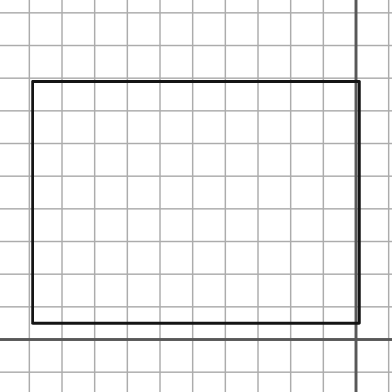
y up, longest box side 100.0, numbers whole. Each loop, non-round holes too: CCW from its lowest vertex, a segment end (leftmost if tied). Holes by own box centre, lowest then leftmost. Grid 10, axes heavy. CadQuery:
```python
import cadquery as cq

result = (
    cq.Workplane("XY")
    .moveTo(-99.0, 5.0)
    .lineTo(1.0, 5.0)
    .lineTo(1.0, 79.0)
    .lineTo(-99.0, 79.0)
    .close()
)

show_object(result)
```